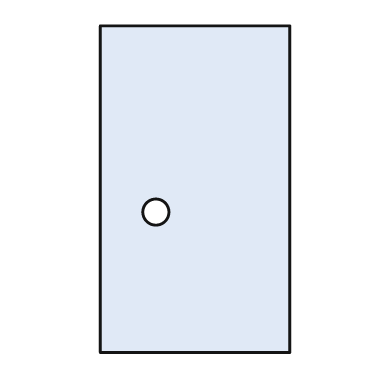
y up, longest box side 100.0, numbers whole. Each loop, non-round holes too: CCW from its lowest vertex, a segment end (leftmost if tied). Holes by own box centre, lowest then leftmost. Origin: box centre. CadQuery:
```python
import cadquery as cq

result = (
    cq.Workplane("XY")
    .moveTo(-29.0, -50.0)
    .lineTo(29.0, -50.0)
    .lineTo(29.0, 50.0)
    .lineTo(-29.0, 50.0)
    .close()
    .moveTo(-12.0, -7.0)
    .circle(4.0)
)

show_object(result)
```